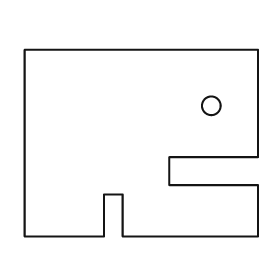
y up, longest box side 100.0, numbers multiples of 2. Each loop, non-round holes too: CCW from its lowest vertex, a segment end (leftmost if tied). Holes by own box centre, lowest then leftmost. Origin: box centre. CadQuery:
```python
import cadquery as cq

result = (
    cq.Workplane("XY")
    .moveTo(-50.0, -40.0)
    .lineTo(-16.0, -40.0)
    .lineTo(-16.0, -22.0)
    .lineTo(-8.0, -22.0)
    .lineTo(-8.0, -40.0)
    .lineTo(50.0, -40.0)
    .lineTo(50.0, -18.0)
    .lineTo(12.0, -18.0)
    .lineTo(12.0, -6.0)
    .lineTo(50.0, -6.0)
    .lineTo(50.0, 40.0)
    .lineTo(-50.0, 40.0)
    .close()
    .moveTo(30.0, 16.0)
    .circle(4.0)
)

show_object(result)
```